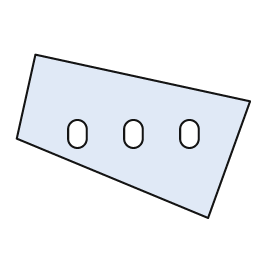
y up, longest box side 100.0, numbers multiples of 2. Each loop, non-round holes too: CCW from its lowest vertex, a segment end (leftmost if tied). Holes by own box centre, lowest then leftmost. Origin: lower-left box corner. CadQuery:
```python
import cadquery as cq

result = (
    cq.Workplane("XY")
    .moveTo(82.0, 0.0)
    .lineTo(100.0, 50.0)
    .lineTo(8.0, 70.0)
    .lineTo(0.0, 34.0)
    .close()
    .moveTo(22.0, 34.0)
    .threePointArc((26.0, 30.0), (30.0, 34.0))
    .lineTo(30.0, 38.0)
    .threePointArc((26.0, 42.0), (22.0, 38.0))
    .close()
    .moveTo(46.0, 34.0)
    .threePointArc((50.0, 30.0), (54.0, 34.0))
    .lineTo(54.0, 38.0)
    .threePointArc((50.0, 42.0), (46.0, 38.0))
    .close()
    .moveTo(70.0, 34.0)
    .threePointArc((74.0, 30.0), (78.0, 34.0))
    .lineTo(78.0, 38.0)
    .threePointArc((74.0, 42.0), (70.0, 38.0))
    .close()
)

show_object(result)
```